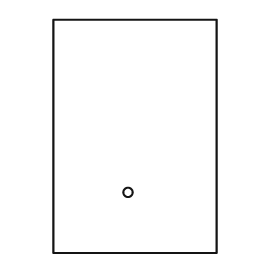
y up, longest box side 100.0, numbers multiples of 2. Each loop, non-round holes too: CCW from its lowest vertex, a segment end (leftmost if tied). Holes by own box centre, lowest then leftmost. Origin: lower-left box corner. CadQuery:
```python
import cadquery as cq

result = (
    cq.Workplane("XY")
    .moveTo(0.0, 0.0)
    .lineTo(70.0, 0.0)
    .lineTo(70.0, 100.0)
    .lineTo(0.0, 100.0)
    .close()
    .moveTo(32.0, 26.0)
    .circle(2.0)
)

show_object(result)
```